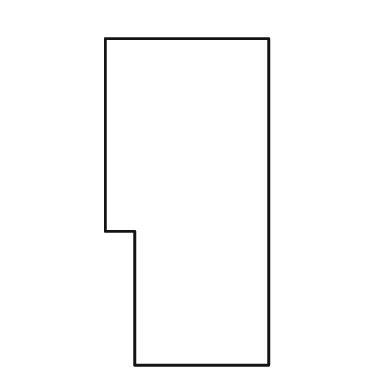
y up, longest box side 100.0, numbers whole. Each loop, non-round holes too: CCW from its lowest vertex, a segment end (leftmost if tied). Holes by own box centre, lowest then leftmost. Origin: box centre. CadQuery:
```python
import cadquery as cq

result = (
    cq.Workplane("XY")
    .moveTo(-16.0, -50.0)
    .lineTo(25.0, -50.0)
    .lineTo(25.0, 50.0)
    .lineTo(-25.0, 50.0)
    .lineTo(-25.0, -9.0)
    .lineTo(-16.0, -9.0)
    .close()
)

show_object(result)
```